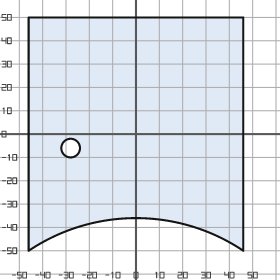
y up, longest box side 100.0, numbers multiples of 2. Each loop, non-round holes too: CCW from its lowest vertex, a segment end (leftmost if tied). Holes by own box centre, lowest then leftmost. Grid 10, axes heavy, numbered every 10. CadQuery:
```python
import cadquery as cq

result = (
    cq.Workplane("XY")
    .moveTo(-46.0, -50.0)
    .threePointArc((0.0, -36.0), (46.0, -50.0))
    .lineTo(46.0, 50.0)
    .lineTo(-46.0, 50.0)
    .close()
    .moveTo(-28.0, -6.0)
    .circle(4.0)
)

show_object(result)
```